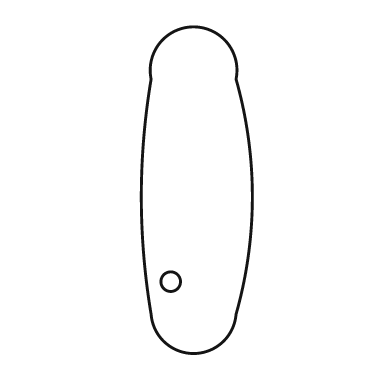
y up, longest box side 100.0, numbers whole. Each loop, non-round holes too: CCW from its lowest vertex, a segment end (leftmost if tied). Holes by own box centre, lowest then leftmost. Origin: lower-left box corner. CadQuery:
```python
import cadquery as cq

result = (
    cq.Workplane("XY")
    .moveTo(3.0, 12.0)
    .threePointArc((16.0, 0.0), (29.0, 12.0))
    .threePointArc((34.0, 48.0), (29.0, 84.0))
    .threePointArc((16.0, 100.0), (3.0, 84.0))
    .threePointArc((0.0, 48.0), (3.0, 12.0))
    .close()
    .moveTo(9.0, 22.0)
    .circle(3.0)
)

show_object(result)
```